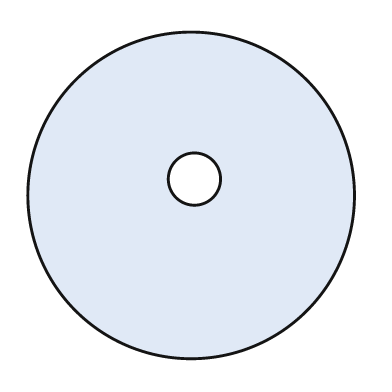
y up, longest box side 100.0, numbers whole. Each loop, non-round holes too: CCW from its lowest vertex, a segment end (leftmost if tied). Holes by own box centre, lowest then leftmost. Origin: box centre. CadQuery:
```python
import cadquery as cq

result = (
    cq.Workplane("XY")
    .moveTo(0.0, 0.0)
    .circle(50.0)
    .moveTo(1.0, 5.0)
    .circle(8.0)
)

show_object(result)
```